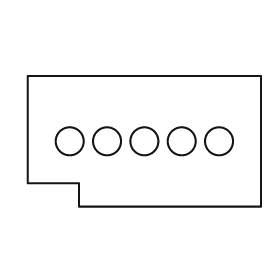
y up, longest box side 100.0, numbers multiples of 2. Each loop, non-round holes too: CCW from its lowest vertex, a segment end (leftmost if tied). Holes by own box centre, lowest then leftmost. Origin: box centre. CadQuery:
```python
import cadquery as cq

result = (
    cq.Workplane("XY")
    .moveTo(-28.0, -28.0)
    .lineTo(50.0, -28.0)
    .lineTo(50.0, 28.0)
    .lineTo(-50.0, 28.0)
    .lineTo(-50.0, -18.0)
    .lineTo(-28.0, -18.0)
    .close()
    .moveTo(-32.0, 0.0)
    .circle(6.0)
    .moveTo(-16.0, 0.0)
    .circle(6.0)
    .moveTo(0.0, 0.0)
    .circle(6.0)
    .moveTo(16.0, 0.0)
    .circle(6.0)
    .moveTo(32.0, 0.0)
    .circle(6.0)
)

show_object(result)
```